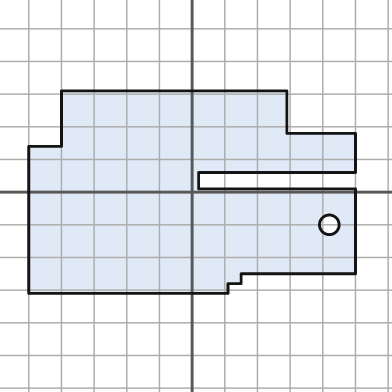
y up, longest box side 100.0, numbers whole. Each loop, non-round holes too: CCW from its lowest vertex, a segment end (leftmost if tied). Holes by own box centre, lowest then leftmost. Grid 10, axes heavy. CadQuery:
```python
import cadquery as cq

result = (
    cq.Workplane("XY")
    .moveTo(-50.0, -31.0)
    .lineTo(11.0, -31.0)
    .lineTo(11.0, -28.0)
    .lineTo(15.0, -28.0)
    .lineTo(15.0, -25.0)
    .lineTo(50.0, -25.0)
    .lineTo(50.0, 1.0)
    .lineTo(2.0, 1.0)
    .lineTo(2.0, 6.0)
    .lineTo(50.0, 6.0)
    .lineTo(50.0, 18.0)
    .lineTo(29.0, 18.0)
    .lineTo(29.0, 31.0)
    .lineTo(-40.0, 31.0)
    .lineTo(-40.0, 14.0)
    .lineTo(-50.0, 14.0)
    .close()
    .moveTo(42.0, -10.0)
    .circle(3.0)
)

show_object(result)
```